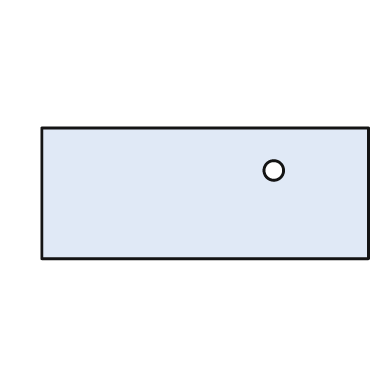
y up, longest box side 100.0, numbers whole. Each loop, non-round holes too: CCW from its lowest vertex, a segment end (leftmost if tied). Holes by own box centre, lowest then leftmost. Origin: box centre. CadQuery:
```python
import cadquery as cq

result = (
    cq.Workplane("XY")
    .moveTo(-50.0, -20.0)
    .lineTo(50.0, -20.0)
    .lineTo(50.0, 20.0)
    .lineTo(-50.0, 20.0)
    .close()
    .moveTo(21.0, 7.0)
    .circle(3.0)
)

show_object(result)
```